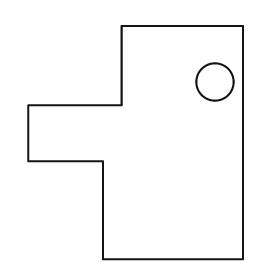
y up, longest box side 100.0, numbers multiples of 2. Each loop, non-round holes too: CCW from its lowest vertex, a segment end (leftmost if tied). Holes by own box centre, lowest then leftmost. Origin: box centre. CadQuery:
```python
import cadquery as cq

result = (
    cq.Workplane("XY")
    .moveTo(-14.0, -50.0)
    .lineTo(46.0, -50.0)
    .lineTo(46.0, 50.0)
    .lineTo(-6.0, 50.0)
    .lineTo(-6.0, 16.0)
    .lineTo(-46.0, 16.0)
    .lineTo(-46.0, -8.0)
    .lineTo(-14.0, -8.0)
    .close()
    .moveTo(34.0, 26.0)
    .circle(8.0)
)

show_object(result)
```